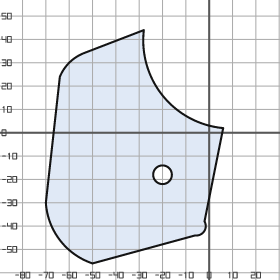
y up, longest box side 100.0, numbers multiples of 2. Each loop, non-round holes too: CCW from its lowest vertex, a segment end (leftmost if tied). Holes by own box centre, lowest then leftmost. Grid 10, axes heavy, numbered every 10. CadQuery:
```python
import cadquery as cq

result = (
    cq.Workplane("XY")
    .moveTo(-50.0, -56.0)
    .lineTo(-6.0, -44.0)
    .threePointArc((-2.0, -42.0), (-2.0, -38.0))
    .lineTo(6.0, 2.0)
    .threePointArc((-20.0, 16.0), (-28.0, 44.0))
    .lineTo(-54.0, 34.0)
    .threePointArc((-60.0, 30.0), (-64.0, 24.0))
    .lineTo(-70.0, -30.0)
    .threePointArc((-64.0, -46.0), (-50.0, -56.0))
    .close()
    .moveTo(-20.0, -18.0)
    .circle(4.0)
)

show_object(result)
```